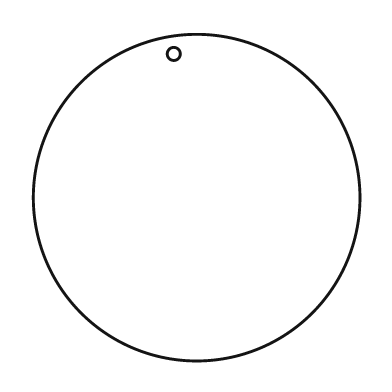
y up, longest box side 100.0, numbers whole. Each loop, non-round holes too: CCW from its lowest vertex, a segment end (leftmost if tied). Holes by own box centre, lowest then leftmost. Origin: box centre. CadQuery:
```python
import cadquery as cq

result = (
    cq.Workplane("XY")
    .moveTo(0.0, 0.0)
    .circle(50.0)
    .moveTo(-7.0, 44.0)
    .circle(2.0)
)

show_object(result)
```